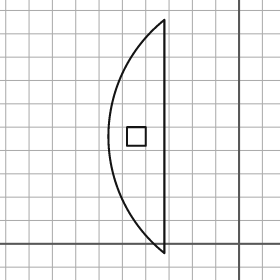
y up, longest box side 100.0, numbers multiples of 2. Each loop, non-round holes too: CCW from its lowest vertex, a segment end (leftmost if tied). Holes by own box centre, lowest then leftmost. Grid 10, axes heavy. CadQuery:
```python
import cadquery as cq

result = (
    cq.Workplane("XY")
    .moveTo(-32.0, -4.0)
    .lineTo(-32.0, 96.0)
    .threePointArc((-56.0, 46.0), (-32.0, -4.0))
    .close()
    .moveTo(-48.0, 42.0)
    .lineTo(-40.0, 42.0)
    .lineTo(-40.0, 50.0)
    .lineTo(-48.0, 50.0)
    .close()
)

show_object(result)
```